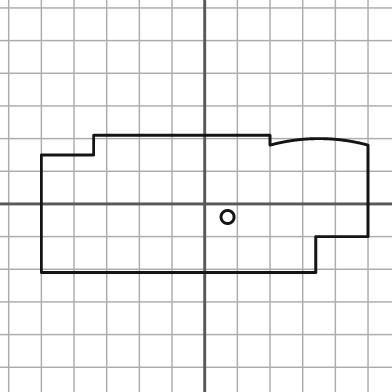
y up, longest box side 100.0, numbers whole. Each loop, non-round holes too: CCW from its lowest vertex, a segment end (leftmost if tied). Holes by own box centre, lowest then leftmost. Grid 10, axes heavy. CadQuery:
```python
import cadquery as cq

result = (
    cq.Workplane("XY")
    .moveTo(-50.0, -21.0)
    .lineTo(34.0, -21.0)
    .lineTo(34.0, -10.0)
    .lineTo(50.0, -10.0)
    .lineTo(50.0, 18.0)
    .threePointArc((35.0, 20.0), (20.0, 18.0))
    .lineTo(20.0, 21.0)
    .lineTo(-34.0, 21.0)
    .lineTo(-34.0, 15.0)
    .lineTo(-50.0, 15.0)
    .close()
    .moveTo(7.0, -4.0)
    .circle(2.0)
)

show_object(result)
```